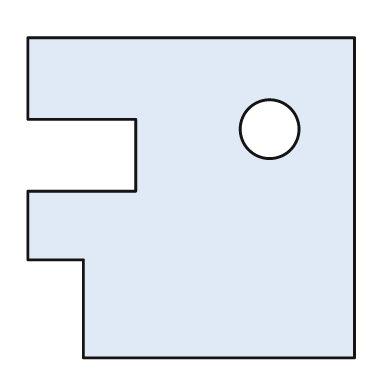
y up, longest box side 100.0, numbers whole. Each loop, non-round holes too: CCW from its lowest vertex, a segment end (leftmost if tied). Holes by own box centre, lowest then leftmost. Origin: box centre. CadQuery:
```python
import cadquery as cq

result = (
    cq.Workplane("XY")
    .moveTo(-33.0, -49.0)
    .lineTo(50.0, -49.0)
    .lineTo(50.0, 49.0)
    .lineTo(-50.0, 49.0)
    .lineTo(-50.0, 24.0)
    .lineTo(-17.0, 24.0)
    .lineTo(-17.0, 2.0)
    .lineTo(-50.0, 2.0)
    .lineTo(-50.0, -19.0)
    .lineTo(-33.0, -19.0)
    .close()
    .moveTo(24.0, 21.0)
    .circle(9.0)
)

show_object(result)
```